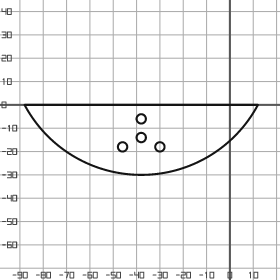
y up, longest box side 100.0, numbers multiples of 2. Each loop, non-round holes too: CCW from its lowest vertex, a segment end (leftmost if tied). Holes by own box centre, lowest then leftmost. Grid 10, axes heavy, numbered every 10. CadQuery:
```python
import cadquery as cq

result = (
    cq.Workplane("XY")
    .moveTo(-88.0, 0.0)
    .threePointArc((-38.0, -30.0), (12.0, 0.0))
    .close()
    .moveTo(-46.0, -18.0)
    .circle(2.0)
    .moveTo(-30.0, -18.0)
    .circle(2.0)
    .moveTo(-38.0, -14.0)
    .circle(2.0)
    .moveTo(-38.0, -6.0)
    .circle(2.0)
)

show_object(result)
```